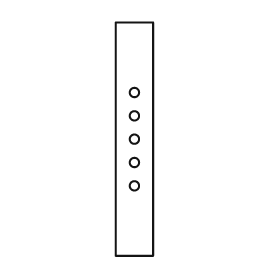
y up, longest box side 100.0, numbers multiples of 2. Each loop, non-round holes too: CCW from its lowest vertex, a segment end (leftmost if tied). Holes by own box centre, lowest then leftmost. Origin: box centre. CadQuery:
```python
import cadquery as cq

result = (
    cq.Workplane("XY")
    .moveTo(-8.0, -50.0)
    .lineTo(8.0, -50.0)
    .lineTo(8.0, 50.0)
    .lineTo(-8.0, 50.0)
    .close()
    .moveTo(0.0, -20.0)
    .circle(2.0)
    .moveTo(0.0, -10.0)
    .circle(2.0)
    .moveTo(0.0, 0.0)
    .circle(2.0)
    .moveTo(0.0, 10.0)
    .circle(2.0)
    .moveTo(0.0, 20.0)
    .circle(2.0)
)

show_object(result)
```